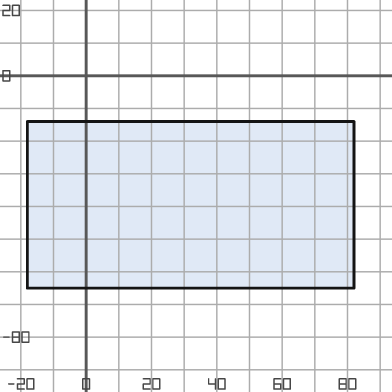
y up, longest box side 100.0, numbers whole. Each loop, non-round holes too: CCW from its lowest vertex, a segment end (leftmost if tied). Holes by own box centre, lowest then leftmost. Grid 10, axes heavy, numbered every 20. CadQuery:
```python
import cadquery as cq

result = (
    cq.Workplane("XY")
    .moveTo(-18.0, -65.0)
    .lineTo(82.0, -65.0)
    .lineTo(82.0, -14.0)
    .lineTo(-18.0, -14.0)
    .close()
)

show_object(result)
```